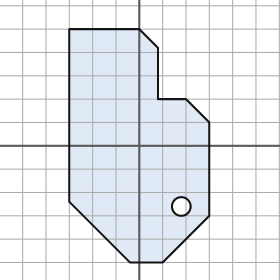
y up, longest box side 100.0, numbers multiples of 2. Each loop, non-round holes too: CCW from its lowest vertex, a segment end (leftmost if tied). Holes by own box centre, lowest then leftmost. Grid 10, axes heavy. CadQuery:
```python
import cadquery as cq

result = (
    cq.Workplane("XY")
    .moveTo(-4.0, -50.0)
    .lineTo(10.0, -50.0)
    .lineTo(30.0, -30.0)
    .lineTo(30.0, 10.0)
    .lineTo(20.0, 20.0)
    .lineTo(8.0, 20.0)
    .lineTo(8.0, 42.0)
    .lineTo(0.0, 50.0)
    .lineTo(-30.0, 50.0)
    .lineTo(-30.0, -24.0)
    .close()
    .moveTo(18.0, -26.0)
    .circle(4.0)
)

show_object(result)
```